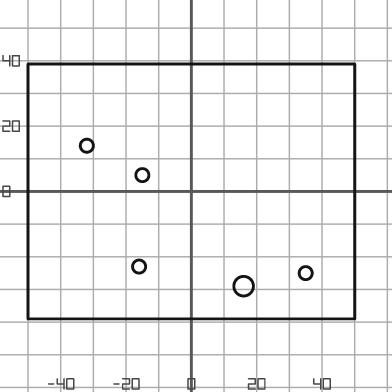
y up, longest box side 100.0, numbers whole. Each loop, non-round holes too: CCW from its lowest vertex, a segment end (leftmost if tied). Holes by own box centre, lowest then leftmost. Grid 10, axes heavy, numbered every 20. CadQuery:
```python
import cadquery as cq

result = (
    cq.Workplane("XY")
    .moveTo(-50.0, -39.0)
    .lineTo(50.0, -39.0)
    .lineTo(50.0, 39.0)
    .lineTo(-50.0, 39.0)
    .close()
    .moveTo(16.0, -29.0)
    .circle(3.0)
    .moveTo(35.0, -25.0)
    .circle(2.0)
    .moveTo(-16.0, -23.0)
    .circle(2.0)
    .moveTo(-15.0, 5.0)
    .circle(2.0)
    .moveTo(-32.0, 14.0)
    .circle(2.0)
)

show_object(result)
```